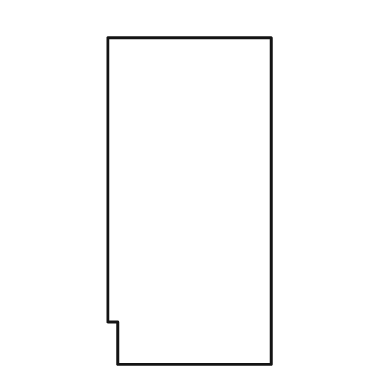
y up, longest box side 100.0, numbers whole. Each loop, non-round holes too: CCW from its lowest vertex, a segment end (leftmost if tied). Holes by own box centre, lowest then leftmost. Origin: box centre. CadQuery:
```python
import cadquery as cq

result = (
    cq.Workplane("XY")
    .moveTo(-22.0, -50.0)
    .lineTo(25.0, -50.0)
    .lineTo(25.0, 50.0)
    .lineTo(-25.0, 50.0)
    .lineTo(-25.0, -37.0)
    .lineTo(-22.0, -37.0)
    .close()
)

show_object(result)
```